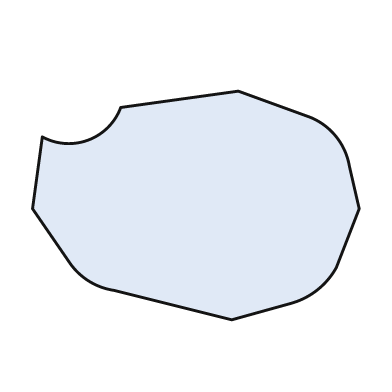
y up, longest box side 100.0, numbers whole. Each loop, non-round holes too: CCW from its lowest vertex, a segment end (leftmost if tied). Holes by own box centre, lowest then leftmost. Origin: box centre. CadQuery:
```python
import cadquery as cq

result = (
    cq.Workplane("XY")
    .moveTo(11.0, -35.0)
    .lineTo(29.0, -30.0)
    .threePointArc((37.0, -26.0), (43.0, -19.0))
    .lineTo(50.0, -1.0)
    .lineTo(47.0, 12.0)
    .threePointArc((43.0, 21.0), (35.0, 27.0))
    .lineTo(13.0, 35.0)
    .lineTo(-23.0, 30.0)
    .threePointArc((-33.0, 20.0), (-47.0, 21.0))
    .lineTo(-50.0, -1.0)
    .lineTo(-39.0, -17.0)
    .threePointArc((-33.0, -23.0), (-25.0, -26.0))
    .close()
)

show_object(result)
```